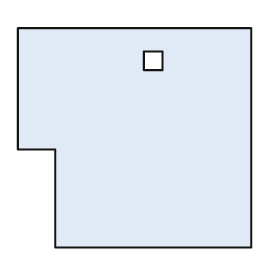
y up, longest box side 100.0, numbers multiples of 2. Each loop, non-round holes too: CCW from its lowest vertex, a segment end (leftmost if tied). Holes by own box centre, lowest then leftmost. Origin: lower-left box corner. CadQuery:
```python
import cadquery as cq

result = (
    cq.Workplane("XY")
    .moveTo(16.0, 0.0)
    .lineTo(100.0, 0.0)
    .lineTo(100.0, 94.0)
    .lineTo(0.0, 94.0)
    .lineTo(0.0, 42.0)
    .lineTo(16.0, 42.0)
    .close()
    .moveTo(54.0, 76.0)
    .lineTo(62.0, 76.0)
    .lineTo(62.0, 84.0)
    .lineTo(54.0, 84.0)
    .close()
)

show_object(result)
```